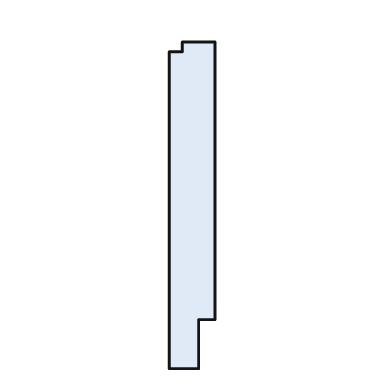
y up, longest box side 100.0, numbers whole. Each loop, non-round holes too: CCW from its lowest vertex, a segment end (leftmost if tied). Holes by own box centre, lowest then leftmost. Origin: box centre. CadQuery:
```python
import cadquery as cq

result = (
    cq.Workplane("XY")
    .moveTo(-7.0, -50.0)
    .lineTo(2.0, -50.0)
    .lineTo(2.0, -35.0)
    .lineTo(7.0, -35.0)
    .lineTo(7.0, 50.0)
    .lineTo(-3.0, 50.0)
    .lineTo(-3.0, 47.0)
    .lineTo(-7.0, 47.0)
    .close()
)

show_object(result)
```